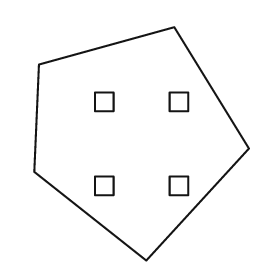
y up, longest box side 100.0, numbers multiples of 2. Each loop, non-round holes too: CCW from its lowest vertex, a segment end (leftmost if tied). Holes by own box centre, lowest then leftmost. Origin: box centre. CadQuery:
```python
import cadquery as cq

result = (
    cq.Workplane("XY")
    .moveTo(2.0, -50.0)
    .lineTo(46.0, -2.0)
    .lineTo(14.0, 50.0)
    .lineTo(-44.0, 34.0)
    .lineTo(-46.0, -12.0)
    .close()
    .moveTo(-20.0, -22.0)
    .lineTo(-12.0, -22.0)
    .lineTo(-12.0, -14.0)
    .lineTo(-20.0, -14.0)
    .close()
    .moveTo(12.0, -22.0)
    .lineTo(20.0, -22.0)
    .lineTo(20.0, -14.0)
    .lineTo(12.0, -14.0)
    .close()
    .moveTo(-20.0, 14.0)
    .lineTo(-12.0, 14.0)
    .lineTo(-12.0, 22.0)
    .lineTo(-20.0, 22.0)
    .close()
    .moveTo(12.0, 14.0)
    .lineTo(20.0, 14.0)
    .lineTo(20.0, 22.0)
    .lineTo(12.0, 22.0)
    .close()
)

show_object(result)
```